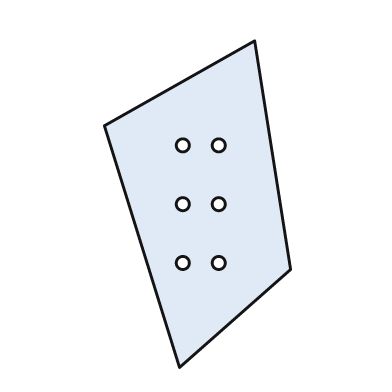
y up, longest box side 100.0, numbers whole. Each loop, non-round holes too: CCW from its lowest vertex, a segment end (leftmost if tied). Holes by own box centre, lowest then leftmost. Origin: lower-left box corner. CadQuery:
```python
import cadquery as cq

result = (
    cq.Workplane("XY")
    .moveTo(23.0, 0.0)
    .lineTo(57.0, 30.0)
    .lineTo(46.0, 100.0)
    .lineTo(0.0, 74.0)
    .close()
    .moveTo(24.0, 32.0)
    .circle(2.0)
    .moveTo(35.0, 32.0)
    .circle(2.0)
    .moveTo(24.0, 50.0)
    .circle(2.0)
    .moveTo(35.0, 50.0)
    .circle(2.0)
    .moveTo(24.0, 68.0)
    .circle(2.0)
    .moveTo(35.0, 68.0)
    .circle(2.0)
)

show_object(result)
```